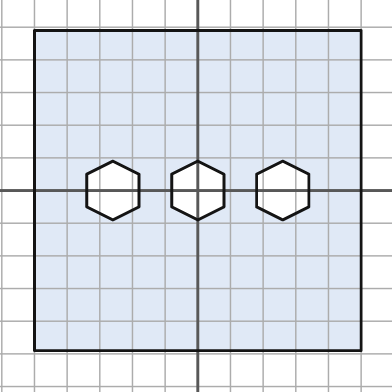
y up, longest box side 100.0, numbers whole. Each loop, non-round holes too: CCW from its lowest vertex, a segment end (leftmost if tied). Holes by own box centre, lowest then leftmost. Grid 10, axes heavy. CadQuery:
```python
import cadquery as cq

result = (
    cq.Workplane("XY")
    .moveTo(-50.0, -49.0)
    .lineTo(50.0, -49.0)
    .lineTo(50.0, 49.0)
    .lineTo(-50.0, 49.0)
    .close()
    .moveTo(-26.0, -9.0)
    .lineTo(-18.0, -5.0)
    .lineTo(-18.0, 5.0)
    .lineTo(-26.0, 9.0)
    .lineTo(-34.0, 5.0)
    .lineTo(-34.0, -5.0)
    .close()
    .moveTo(0.0, -9.0)
    .lineTo(8.0, -5.0)
    .lineTo(8.0, 5.0)
    .lineTo(0.0, 9.0)
    .lineTo(-8.0, 5.0)
    .lineTo(-8.0, -5.0)
    .close()
    .moveTo(26.0, -9.0)
    .lineTo(34.0, -5.0)
    .lineTo(34.0, 5.0)
    .lineTo(26.0, 9.0)
    .lineTo(18.0, 5.0)
    .lineTo(18.0, -5.0)
    .close()
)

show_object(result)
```